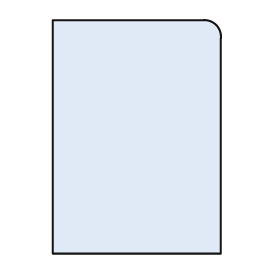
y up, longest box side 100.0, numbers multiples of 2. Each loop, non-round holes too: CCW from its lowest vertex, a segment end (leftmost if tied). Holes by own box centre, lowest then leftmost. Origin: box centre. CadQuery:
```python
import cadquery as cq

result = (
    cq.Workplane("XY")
    .moveTo(-36.0, -50.0)
    .lineTo(36.0, -50.0)
    .lineTo(36.0, 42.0)
    .threePointArc((34.0, 48.0), (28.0, 50.0))
    .lineTo(-36.0, 50.0)
    .close()
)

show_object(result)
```